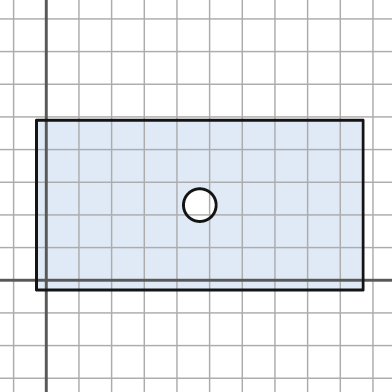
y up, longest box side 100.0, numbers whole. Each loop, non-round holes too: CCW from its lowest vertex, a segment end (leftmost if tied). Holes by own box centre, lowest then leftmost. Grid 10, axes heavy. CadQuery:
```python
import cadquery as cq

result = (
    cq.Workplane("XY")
    .moveTo(-3.0, -3.0)
    .lineTo(97.0, -3.0)
    .lineTo(97.0, 49.0)
    .lineTo(-3.0, 49.0)
    .close()
    .moveTo(47.0, 23.0)
    .circle(5.0)
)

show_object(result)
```